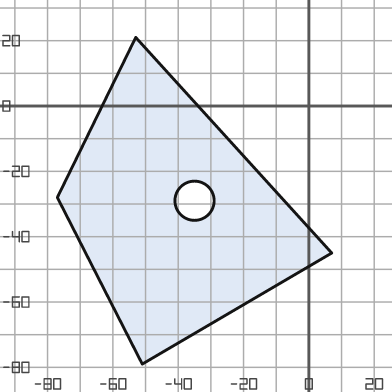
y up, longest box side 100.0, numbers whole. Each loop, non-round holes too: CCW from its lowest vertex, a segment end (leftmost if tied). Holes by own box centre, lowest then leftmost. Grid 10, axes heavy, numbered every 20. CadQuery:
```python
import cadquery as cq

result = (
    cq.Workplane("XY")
    .moveTo(-51.0, -79.0)
    .lineTo(7.0, -45.0)
    .lineTo(-53.0, 21.0)
    .lineTo(-77.0, -28.0)
    .close()
    .moveTo(-35.0, -29.0)
    .circle(6.0)
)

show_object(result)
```